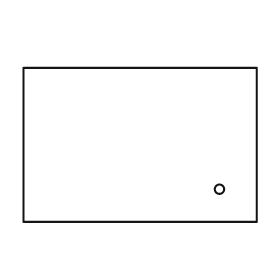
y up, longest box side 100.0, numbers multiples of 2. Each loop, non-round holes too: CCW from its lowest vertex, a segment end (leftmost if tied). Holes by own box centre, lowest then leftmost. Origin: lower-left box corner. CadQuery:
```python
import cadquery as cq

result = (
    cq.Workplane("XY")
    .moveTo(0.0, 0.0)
    .lineTo(100.0, 0.0)
    .lineTo(100.0, 66.0)
    .lineTo(0.0, 66.0)
    .close()
    .moveTo(84.0, 14.0)
    .circle(2.0)
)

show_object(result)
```